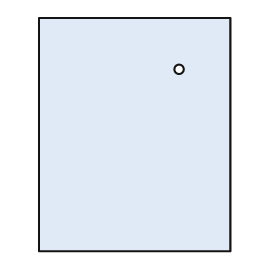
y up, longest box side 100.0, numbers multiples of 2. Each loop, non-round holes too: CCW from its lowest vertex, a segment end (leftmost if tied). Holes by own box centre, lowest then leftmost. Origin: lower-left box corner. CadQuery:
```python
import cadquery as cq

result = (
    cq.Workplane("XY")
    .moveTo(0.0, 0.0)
    .lineTo(82.0, 0.0)
    .lineTo(82.0, 100.0)
    .lineTo(0.0, 100.0)
    .close()
    .moveTo(60.0, 78.0)
    .circle(2.0)
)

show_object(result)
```